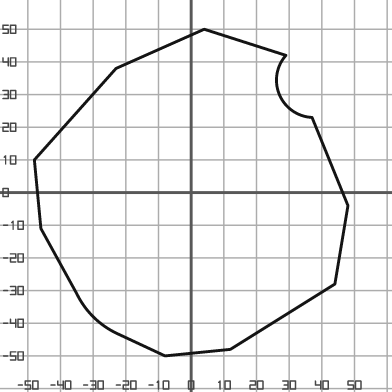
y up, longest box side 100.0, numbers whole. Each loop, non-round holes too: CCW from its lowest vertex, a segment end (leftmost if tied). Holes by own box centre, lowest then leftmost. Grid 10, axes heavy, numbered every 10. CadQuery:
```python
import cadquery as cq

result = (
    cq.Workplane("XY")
    .moveTo(-8.0, -50.0)
    .lineTo(12.0, -48.0)
    .lineTo(44.0, -28.0)
    .lineTo(48.0, -4.0)
    .lineTo(37.0, 23.0)
    .threePointArc((27.0, 30.0), (29.0, 42.0))
    .lineTo(4.0, 50.0)
    .lineTo(-23.0, 38.0)
    .lineTo(-48.0, 10.0)
    .lineTo(-46.0, -11.0)
    .lineTo(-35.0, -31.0)
    .threePointArc((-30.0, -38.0), (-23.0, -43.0))
    .close()
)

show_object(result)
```